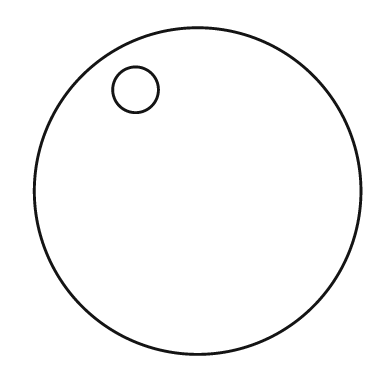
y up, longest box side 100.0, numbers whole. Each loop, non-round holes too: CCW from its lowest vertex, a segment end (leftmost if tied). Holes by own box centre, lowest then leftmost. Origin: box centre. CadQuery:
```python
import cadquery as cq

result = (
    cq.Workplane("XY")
    .moveTo(0.0, 0.0)
    .circle(50.0)
    .moveTo(-19.0, 31.0)
    .circle(7.0)
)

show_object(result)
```